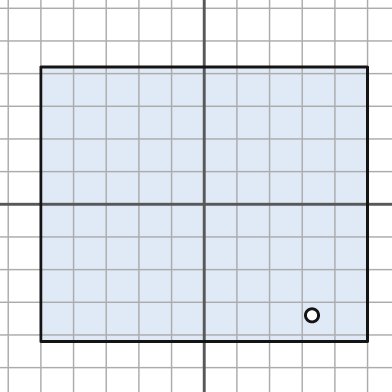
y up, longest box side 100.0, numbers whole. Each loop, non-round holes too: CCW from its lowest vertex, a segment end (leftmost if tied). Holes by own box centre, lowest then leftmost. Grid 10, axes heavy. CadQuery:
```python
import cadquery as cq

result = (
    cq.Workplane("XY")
    .moveTo(-50.0, -42.0)
    .lineTo(50.0, -42.0)
    .lineTo(50.0, 42.0)
    .lineTo(-50.0, 42.0)
    .close()
    .moveTo(33.0, -34.0)
    .circle(2.0)
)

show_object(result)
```